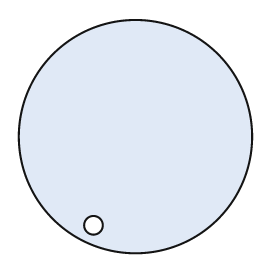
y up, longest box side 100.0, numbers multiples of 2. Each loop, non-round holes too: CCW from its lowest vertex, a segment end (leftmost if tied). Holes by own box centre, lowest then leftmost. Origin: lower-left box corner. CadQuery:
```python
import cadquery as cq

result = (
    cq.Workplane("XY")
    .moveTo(50.0, 50.0)
    .circle(50.0)
    .moveTo(32.0, 12.0)
    .circle(4.0)
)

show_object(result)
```